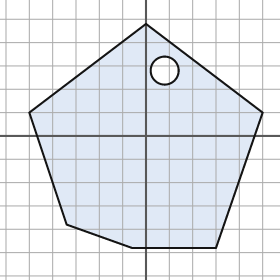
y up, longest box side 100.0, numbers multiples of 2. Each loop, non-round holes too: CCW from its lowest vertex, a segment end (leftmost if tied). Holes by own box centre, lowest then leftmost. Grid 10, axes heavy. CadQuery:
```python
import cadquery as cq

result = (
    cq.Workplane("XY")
    .moveTo(-6.0, -48.0)
    .lineTo(30.0, -48.0)
    .lineTo(50.0, 10.0)
    .lineTo(0.0, 48.0)
    .lineTo(-50.0, 10.0)
    .lineTo(-34.0, -38.0)
    .close()
    .moveTo(8.0, 28.0)
    .circle(6.0)
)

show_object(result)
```